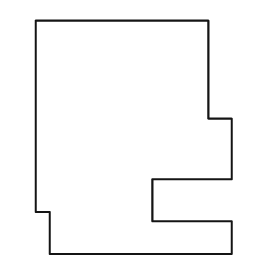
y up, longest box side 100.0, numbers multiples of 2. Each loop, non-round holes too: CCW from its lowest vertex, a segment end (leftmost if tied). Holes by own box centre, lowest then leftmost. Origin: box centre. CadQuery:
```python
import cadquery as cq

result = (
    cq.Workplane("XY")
    .moveTo(-36.0, -50.0)
    .lineTo(42.0, -50.0)
    .lineTo(42.0, -36.0)
    .lineTo(8.0, -36.0)
    .lineTo(8.0, -18.0)
    .lineTo(42.0, -18.0)
    .lineTo(42.0, 8.0)
    .lineTo(32.0, 8.0)
    .lineTo(32.0, 50.0)
    .lineTo(-42.0, 50.0)
    .lineTo(-42.0, -32.0)
    .lineTo(-36.0, -32.0)
    .close()
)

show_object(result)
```